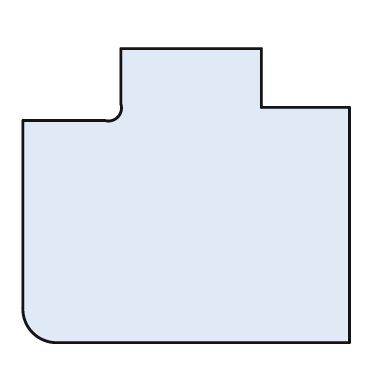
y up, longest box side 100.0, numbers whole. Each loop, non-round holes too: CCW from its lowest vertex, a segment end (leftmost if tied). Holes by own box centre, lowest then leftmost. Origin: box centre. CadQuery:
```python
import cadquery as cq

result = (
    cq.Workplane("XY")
    .moveTo(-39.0, -45.0)
    .lineTo(50.0, -45.0)
    .lineTo(50.0, 27.0)
    .lineTo(23.0, 27.0)
    .lineTo(23.0, 45.0)
    .lineTo(-20.0, 45.0)
    .lineTo(-20.0, 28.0)
    .threePointArc((-21.0, 24.0), (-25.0, 23.0))
    .lineTo(-50.0, 23.0)
    .lineTo(-50.0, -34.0)
    .threePointArc((-47.0, -42.0), (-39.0, -45.0))
    .close()
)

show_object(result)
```